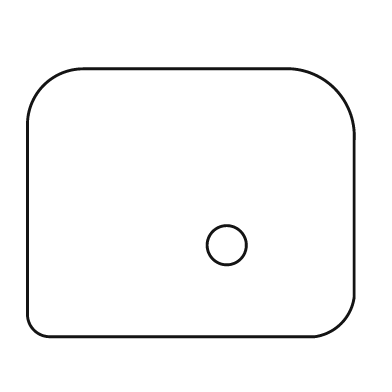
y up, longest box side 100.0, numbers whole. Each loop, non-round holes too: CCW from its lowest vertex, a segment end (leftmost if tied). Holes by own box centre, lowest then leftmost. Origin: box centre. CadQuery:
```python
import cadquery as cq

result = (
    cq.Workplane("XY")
    .moveTo(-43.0, -41.0)
    .lineTo(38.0, -41.0)
    .threePointArc((46.0, -37.0), (50.0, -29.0))
    .lineTo(50.0, 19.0)
    .threePointArc((44.0, 35.0), (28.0, 41.0))
    .lineTo(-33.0, 41.0)
    .threePointArc((-45.0, 36.0), (-50.0, 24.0))
    .lineTo(-50.0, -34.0)
    .threePointArc((-48.0, -39.0), (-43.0, -41.0))
    .close()
    .moveTo(11.0, -13.0)
    .circle(6.0)
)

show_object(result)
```